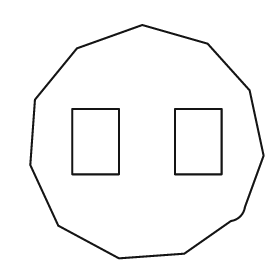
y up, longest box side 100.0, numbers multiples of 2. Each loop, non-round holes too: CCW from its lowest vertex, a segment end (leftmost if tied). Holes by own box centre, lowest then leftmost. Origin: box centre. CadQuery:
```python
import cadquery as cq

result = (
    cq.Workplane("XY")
    .moveTo(-12.0, -50.0)
    .lineTo(16.0, -48.0)
    .lineTo(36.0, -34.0)
    .threePointArc((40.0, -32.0), (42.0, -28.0))
    .lineTo(50.0, -6.0)
    .lineTo(44.0, 22.0)
    .lineTo(26.0, 42.0)
    .lineTo(-2.0, 50.0)
    .lineTo(-30.0, 40.0)
    .lineTo(-48.0, 18.0)
    .lineTo(-50.0, -10.0)
    .lineTo(-38.0, -36.0)
    .close()
    .moveTo(-32.0, -14.0)
    .lineTo(-12.0, -14.0)
    .lineTo(-12.0, 14.0)
    .lineTo(-32.0, 14.0)
    .close()
    .moveTo(12.0, -14.0)
    .lineTo(32.0, -14.0)
    .lineTo(32.0, 14.0)
    .lineTo(12.0, 14.0)
    .close()
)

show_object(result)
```